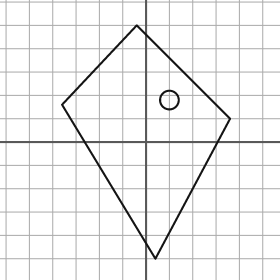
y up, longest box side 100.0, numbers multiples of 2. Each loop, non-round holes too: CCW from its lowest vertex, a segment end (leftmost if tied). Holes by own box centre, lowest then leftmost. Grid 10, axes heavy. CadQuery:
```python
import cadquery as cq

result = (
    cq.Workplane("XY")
    .moveTo(4.0, -50.0)
    .lineTo(36.0, 10.0)
    .lineTo(-4.0, 50.0)
    .lineTo(-36.0, 16.0)
    .close()
    .moveTo(10.0, 18.0)
    .circle(4.0)
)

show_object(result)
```